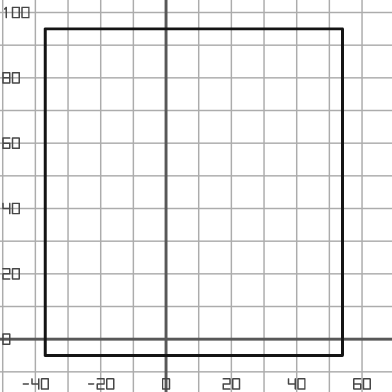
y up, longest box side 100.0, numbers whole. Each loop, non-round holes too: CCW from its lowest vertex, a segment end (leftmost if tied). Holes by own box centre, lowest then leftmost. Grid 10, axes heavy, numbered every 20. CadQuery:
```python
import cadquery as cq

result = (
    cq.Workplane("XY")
    .moveTo(-37.0, -5.0)
    .lineTo(54.0, -5.0)
    .lineTo(54.0, 95.0)
    .lineTo(-37.0, 95.0)
    .close()
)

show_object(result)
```